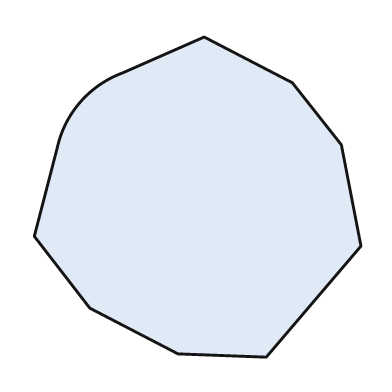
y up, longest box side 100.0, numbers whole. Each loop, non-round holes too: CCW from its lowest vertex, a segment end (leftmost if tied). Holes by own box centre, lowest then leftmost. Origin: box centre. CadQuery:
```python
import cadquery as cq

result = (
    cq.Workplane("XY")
    .moveTo(21.0, -49.0)
    .lineTo(50.0, -15.0)
    .lineTo(44.0, 16.0)
    .lineTo(29.0, 35.0)
    .lineTo(2.0, 49.0)
    .lineTo(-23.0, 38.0)
    .threePointArc((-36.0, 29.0), (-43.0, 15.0))
    .lineTo(-50.0, -12.0)
    .lineTo(-33.0, -34.0)
    .lineTo(-6.0, -48.0)
    .close()
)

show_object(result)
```